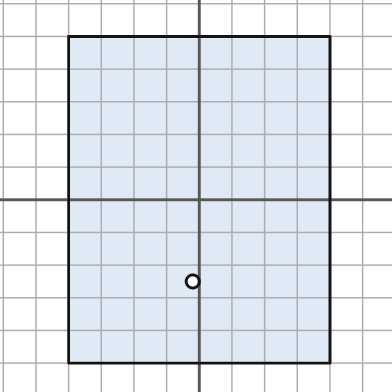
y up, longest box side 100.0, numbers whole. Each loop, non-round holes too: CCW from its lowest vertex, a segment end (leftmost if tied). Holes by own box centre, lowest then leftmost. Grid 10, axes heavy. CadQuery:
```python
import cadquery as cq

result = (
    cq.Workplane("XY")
    .moveTo(-40.0, -50.0)
    .lineTo(40.0, -50.0)
    .lineTo(40.0, 50.0)
    .lineTo(-40.0, 50.0)
    .close()
    .moveTo(-2.0, -25.0)
    .circle(2.0)
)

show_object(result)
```